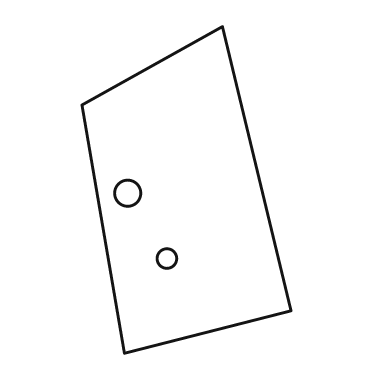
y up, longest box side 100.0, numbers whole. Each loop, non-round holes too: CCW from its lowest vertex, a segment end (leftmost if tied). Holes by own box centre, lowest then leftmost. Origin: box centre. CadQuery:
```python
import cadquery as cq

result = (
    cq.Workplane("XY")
    .moveTo(-19.0, -50.0)
    .lineTo(32.0, -37.0)
    .lineTo(11.0, 50.0)
    .lineTo(-32.0, 26.0)
    .close()
    .moveTo(-6.0, -21.0)
    .circle(3.0)
    .moveTo(-18.0, -1.0)
    .circle(4.0)
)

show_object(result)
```